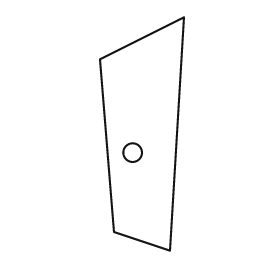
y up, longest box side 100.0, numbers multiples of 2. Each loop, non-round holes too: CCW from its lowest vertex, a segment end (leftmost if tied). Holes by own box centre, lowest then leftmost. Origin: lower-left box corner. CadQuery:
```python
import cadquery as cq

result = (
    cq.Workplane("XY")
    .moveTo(30.0, 0.0)
    .lineTo(36.0, 100.0)
    .lineTo(0.0, 82.0)
    .lineTo(6.0, 8.0)
    .close()
    .moveTo(14.0, 42.0)
    .circle(4.0)
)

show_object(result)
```